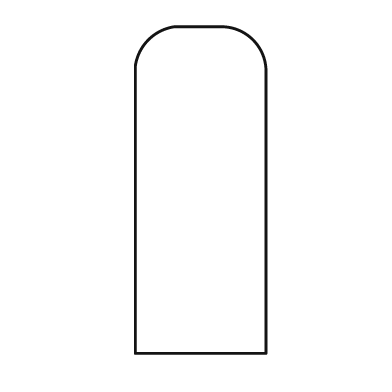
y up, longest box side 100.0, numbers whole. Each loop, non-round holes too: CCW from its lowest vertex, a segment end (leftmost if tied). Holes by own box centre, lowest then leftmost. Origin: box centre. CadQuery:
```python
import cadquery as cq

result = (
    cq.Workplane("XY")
    .moveTo(-20.0, -50.0)
    .lineTo(20.0, -50.0)
    .lineTo(20.0, 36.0)
    .threePointArc((16.0, 46.0), (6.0, 50.0))
    .lineTo(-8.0, 50.0)
    .threePointArc((-16.0, 46.0), (-20.0, 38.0))
    .close()
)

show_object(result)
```